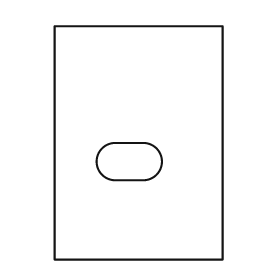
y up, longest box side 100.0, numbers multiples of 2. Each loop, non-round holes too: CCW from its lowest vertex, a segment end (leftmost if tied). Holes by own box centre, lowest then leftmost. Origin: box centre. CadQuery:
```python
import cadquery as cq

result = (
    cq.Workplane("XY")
    .moveTo(-36.0, -50.0)
    .lineTo(36.0, -50.0)
    .lineTo(36.0, 50.0)
    .lineTo(-36.0, 50.0)
    .close()
    .moveTo(-10.0, -16.0)
    .lineTo(2.0, -16.0)
    .threePointArc((10.0, -8.0), (2.0, 0.0))
    .lineTo(-10.0, 0.0)
    .threePointArc((-18.0, -8.0), (-10.0, -16.0))
    .close()
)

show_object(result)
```